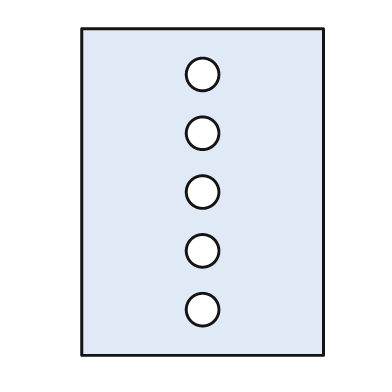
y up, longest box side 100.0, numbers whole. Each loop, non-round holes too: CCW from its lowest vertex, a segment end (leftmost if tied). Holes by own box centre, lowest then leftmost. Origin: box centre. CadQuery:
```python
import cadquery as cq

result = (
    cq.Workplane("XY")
    .moveTo(-37.0, -50.0)
    .lineTo(37.0, -50.0)
    .lineTo(37.0, 50.0)
    .lineTo(-37.0, 50.0)
    .close()
    .moveTo(0.0, -36.0)
    .circle(5.0)
    .moveTo(0.0, -18.0)
    .circle(5.0)
    .moveTo(0.0, 0.0)
    .circle(5.0)
    .moveTo(0.0, 18.0)
    .circle(5.0)
    .moveTo(0.0, 36.0)
    .circle(5.0)
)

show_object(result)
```